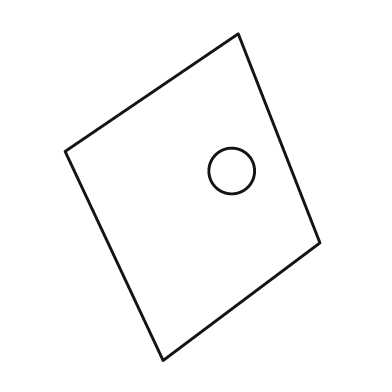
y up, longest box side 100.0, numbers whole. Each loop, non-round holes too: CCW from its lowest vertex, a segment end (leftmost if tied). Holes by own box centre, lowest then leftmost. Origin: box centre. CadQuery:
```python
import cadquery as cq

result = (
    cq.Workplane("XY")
    .moveTo(-9.0, -50.0)
    .lineTo(39.0, -14.0)
    .lineTo(14.0, 50.0)
    .lineTo(-39.0, 14.0)
    .close()
    .moveTo(12.0, 8.0)
    .circle(7.0)
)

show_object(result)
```